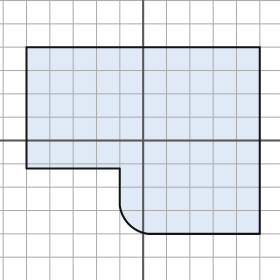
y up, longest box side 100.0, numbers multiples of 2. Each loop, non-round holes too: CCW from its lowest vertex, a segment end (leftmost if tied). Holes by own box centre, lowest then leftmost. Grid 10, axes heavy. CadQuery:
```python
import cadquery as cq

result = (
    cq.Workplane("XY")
    .moveTo(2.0, -40.0)
    .lineTo(50.0, -40.0)
    .lineTo(50.0, 40.0)
    .lineTo(-50.0, 40.0)
    .lineTo(-50.0, -12.0)
    .lineTo(-10.0, -12.0)
    .lineTo(-10.0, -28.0)
    .threePointArc((-6.0, -36.0), (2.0, -40.0))
    .close()
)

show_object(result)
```